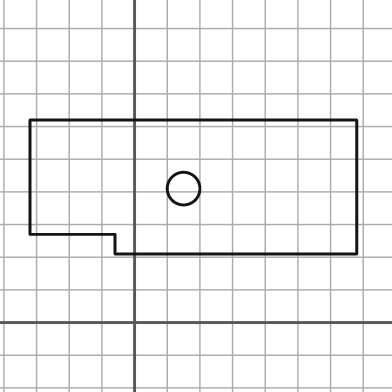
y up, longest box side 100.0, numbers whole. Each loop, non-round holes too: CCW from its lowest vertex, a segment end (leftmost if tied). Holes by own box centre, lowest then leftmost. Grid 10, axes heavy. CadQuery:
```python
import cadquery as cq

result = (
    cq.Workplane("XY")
    .moveTo(-6.0, 21.0)
    .lineTo(68.0, 21.0)
    .lineTo(68.0, 62.0)
    .lineTo(-32.0, 62.0)
    .lineTo(-32.0, 27.0)
    .lineTo(-6.0, 27.0)
    .close()
    .moveTo(15.0, 41.0)
    .circle(5.0)
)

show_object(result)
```